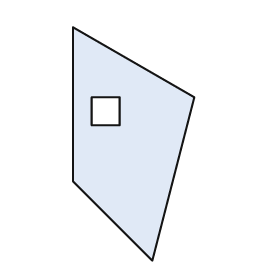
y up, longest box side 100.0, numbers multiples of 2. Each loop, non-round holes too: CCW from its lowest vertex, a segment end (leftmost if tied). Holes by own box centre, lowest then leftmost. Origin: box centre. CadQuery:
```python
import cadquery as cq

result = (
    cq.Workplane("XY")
    .moveTo(8.0, -50.0)
    .lineTo(26.0, 20.0)
    .lineTo(-26.0, 50.0)
    .lineTo(-26.0, -16.0)
    .close()
    .moveTo(-18.0, 8.0)
    .lineTo(-6.0, 8.0)
    .lineTo(-6.0, 20.0)
    .lineTo(-18.0, 20.0)
    .close()
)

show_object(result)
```